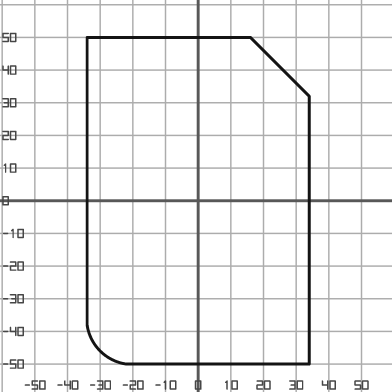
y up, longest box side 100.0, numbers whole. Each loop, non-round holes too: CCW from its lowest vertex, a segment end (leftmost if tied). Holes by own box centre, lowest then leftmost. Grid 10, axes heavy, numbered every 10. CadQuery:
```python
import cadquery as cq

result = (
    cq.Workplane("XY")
    .moveTo(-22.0, -50.0)
    .lineTo(34.0, -50.0)
    .lineTo(34.0, 32.0)
    .lineTo(16.0, 50.0)
    .lineTo(-34.0, 50.0)
    .lineTo(-34.0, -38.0)
    .threePointArc((-30.0, -46.0), (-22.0, -50.0))
    .close()
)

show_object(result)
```